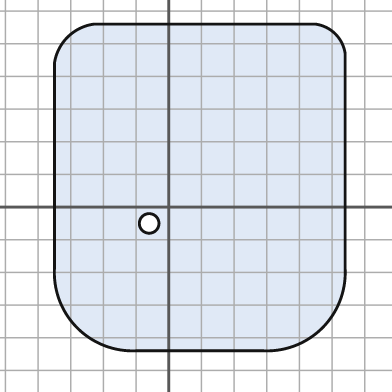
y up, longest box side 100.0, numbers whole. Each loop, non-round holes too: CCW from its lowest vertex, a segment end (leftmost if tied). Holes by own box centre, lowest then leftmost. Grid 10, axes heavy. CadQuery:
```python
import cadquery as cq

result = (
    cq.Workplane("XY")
    .moveTo(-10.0, -44.0)
    .lineTo(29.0, -44.0)
    .threePointArc((47.0, -37.0), (54.0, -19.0))
    .lineTo(54.0, 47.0)
    .threePointArc((51.0, 53.0), (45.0, 56.0))
    .lineTo(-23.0, 56.0)
    .threePointArc((-31.0, 52.0), (-35.0, 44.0))
    .lineTo(-35.0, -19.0)
    .threePointArc((-28.0, -37.0), (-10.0, -44.0))
    .close()
    .moveTo(-6.0, -5.0)
    .circle(3.0)
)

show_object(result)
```